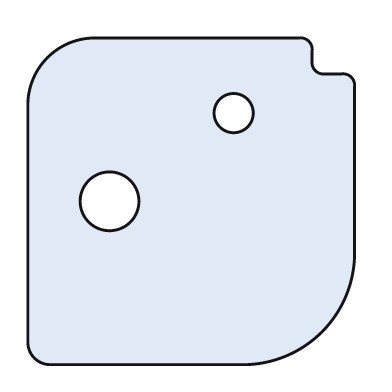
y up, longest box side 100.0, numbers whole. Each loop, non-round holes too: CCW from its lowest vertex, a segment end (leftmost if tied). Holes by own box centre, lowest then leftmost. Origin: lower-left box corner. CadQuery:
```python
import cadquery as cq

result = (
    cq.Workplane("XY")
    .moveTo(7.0, 0.0)
    .lineTo(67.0, 0.0)
    .threePointArc((90.0, 10.0), (100.0, 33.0))
    .lineTo(100.0, 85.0)
    .threePointArc((99.0, 88.0), (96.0, 89.0))
    .lineTo(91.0, 89.0)
    .threePointArc((88.0, 90.0), (87.0, 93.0))
    .lineTo(87.0, 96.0)
    .threePointArc((86.0, 99.0), (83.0, 100.0))
    .lineTo(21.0, 100.0)
    .threePointArc((6.0, 94.0), (0.0, 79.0))
    .lineTo(0.0, 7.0)
    .threePointArc((2.0, 2.0), (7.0, 0.0))
    .close()
    .moveTo(25.0, 50.0)
    .circle(9.0)
    .moveTo(63.0, 77.0)
    .circle(6.0)
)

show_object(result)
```